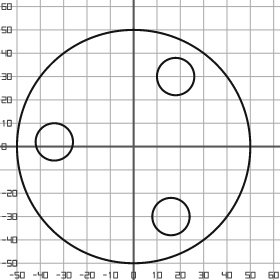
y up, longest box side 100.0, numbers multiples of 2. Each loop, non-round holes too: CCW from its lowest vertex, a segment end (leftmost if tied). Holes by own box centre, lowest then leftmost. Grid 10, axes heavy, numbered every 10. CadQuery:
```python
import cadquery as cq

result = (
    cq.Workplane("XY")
    .moveTo(0.0, 0.0)
    .circle(50.0)
    .moveTo(16.0, -30.0)
    .circle(8.0)
    .moveTo(-34.0, 2.0)
    .circle(8.0)
    .moveTo(18.0, 30.0)
    .circle(8.0)
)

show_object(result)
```